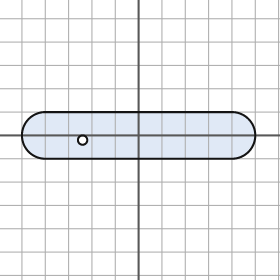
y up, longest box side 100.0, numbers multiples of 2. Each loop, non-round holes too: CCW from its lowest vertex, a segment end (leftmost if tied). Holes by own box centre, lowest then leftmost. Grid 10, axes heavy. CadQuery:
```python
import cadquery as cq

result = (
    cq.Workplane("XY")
    .moveTo(-40.0, -10.0)
    .lineTo(40.0, -10.0)
    .threePointArc((50.0, 0.0), (40.0, 10.0))
    .lineTo(-40.0, 10.0)
    .threePointArc((-50.0, 0.0), (-40.0, -10.0))
    .close()
    .moveTo(-24.0, -2.0)
    .circle(2.0)
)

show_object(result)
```